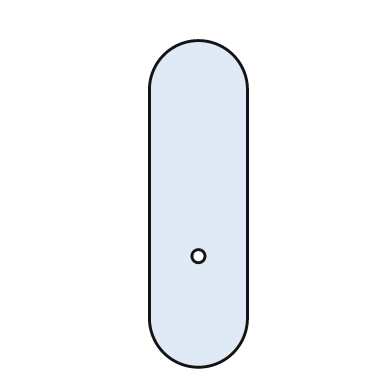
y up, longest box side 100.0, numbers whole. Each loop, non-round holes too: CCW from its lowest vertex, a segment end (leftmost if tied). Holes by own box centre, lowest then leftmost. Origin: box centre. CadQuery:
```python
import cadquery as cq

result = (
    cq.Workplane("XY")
    .moveTo(-15.0, -35.0)
    .threePointArc((0.0, -50.0), (15.0, -35.0))
    .lineTo(15.0, 35.0)
    .threePointArc((0.0, 50.0), (-15.0, 35.0))
    .close()
    .moveTo(0.0, -16.0)
    .circle(2.0)
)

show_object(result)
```